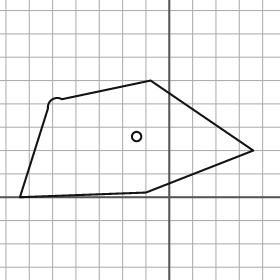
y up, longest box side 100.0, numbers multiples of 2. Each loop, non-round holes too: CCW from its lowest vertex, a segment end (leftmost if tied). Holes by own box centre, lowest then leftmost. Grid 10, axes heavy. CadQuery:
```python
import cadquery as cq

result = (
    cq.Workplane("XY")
    .moveTo(-64.0, 0.0)
    .lineTo(-10.0, 2.0)
    .lineTo(36.0, 20.0)
    .lineTo(-8.0, 50.0)
    .lineTo(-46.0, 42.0)
    .threePointArc((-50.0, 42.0), (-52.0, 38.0))
    .close()
    .moveTo(-14.0, 26.0)
    .circle(2.0)
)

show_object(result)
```